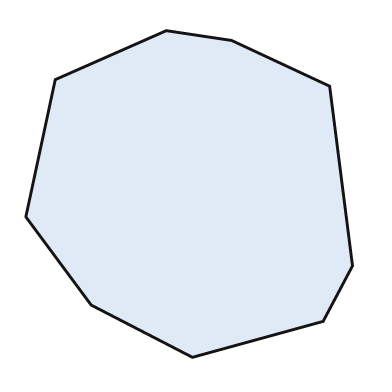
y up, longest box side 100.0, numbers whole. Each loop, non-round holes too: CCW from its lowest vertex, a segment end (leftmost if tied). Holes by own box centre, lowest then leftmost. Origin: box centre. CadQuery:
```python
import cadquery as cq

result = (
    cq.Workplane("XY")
    .moveTo(1.0, -50.0)
    .lineTo(41.0, -39.0)
    .lineTo(50.0, -22.0)
    .lineTo(43.0, 33.0)
    .lineTo(13.0, 47.0)
    .lineTo(-7.0, 50.0)
    .lineTo(-41.0, 35.0)
    .lineTo(-50.0, -7.0)
    .lineTo(-30.0, -34.0)
    .close()
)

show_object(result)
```